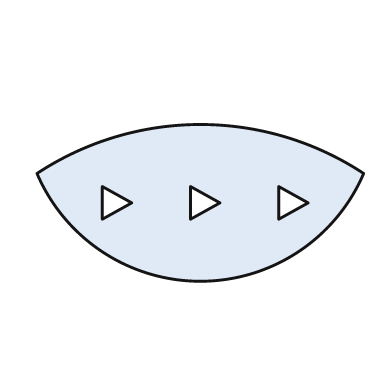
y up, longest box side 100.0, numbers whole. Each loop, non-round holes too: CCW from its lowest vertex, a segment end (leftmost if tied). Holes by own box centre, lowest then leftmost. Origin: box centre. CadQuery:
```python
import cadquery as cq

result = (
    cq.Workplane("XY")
    .moveTo(-50.0, 9.0)
    .threePointArc((0.0, -24.0), (50.0, 9.0))
    .threePointArc((0.0, 24.0), (-50.0, 9.0))
    .close()
    .moveTo(-30.0, -5.0)
    .lineTo(-21.0, 0.0)
    .lineTo(-30.0, 5.0)
    .close()
    .moveTo(-3.0, -5.0)
    .lineTo(6.0, 0.0)
    .lineTo(-3.0, 5.0)
    .close()
    .moveTo(24.0, -5.0)
    .lineTo(33.0, 0.0)
    .lineTo(24.0, 5.0)
    .close()
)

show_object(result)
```